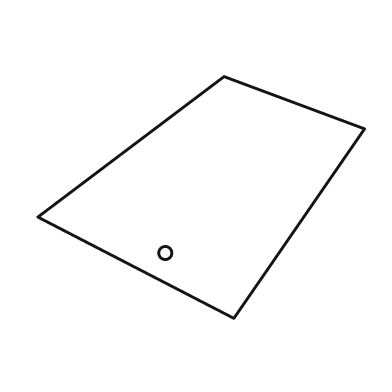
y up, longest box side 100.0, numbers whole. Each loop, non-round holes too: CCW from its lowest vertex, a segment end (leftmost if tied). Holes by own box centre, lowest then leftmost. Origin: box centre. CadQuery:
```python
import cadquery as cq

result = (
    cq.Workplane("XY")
    .moveTo(10.0, -37.0)
    .lineTo(50.0, 21.0)
    .lineTo(7.0, 37.0)
    .lineTo(-50.0, -6.0)
    .close()
    .moveTo(-11.0, -17.0)
    .circle(2.0)
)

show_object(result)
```